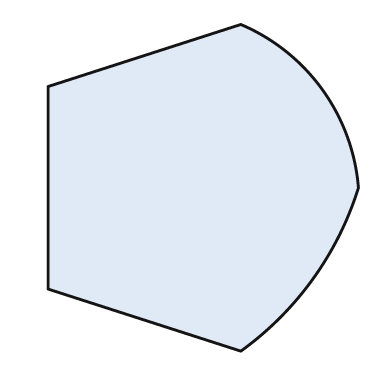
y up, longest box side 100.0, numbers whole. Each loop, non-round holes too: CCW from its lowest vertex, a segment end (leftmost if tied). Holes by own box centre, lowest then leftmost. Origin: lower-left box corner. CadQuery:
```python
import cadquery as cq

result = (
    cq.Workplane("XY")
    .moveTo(59.0, 0.0)
    .threePointArc((81.0, 22.0), (95.0, 50.0))
    .threePointArc((84.0, 80.0), (59.0, 100.0))
    .lineTo(0.0, 81.0)
    .lineTo(0.0, 19.0)
    .close()
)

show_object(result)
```